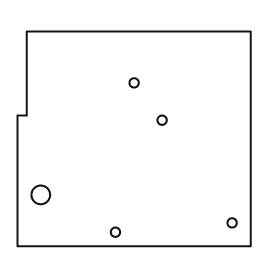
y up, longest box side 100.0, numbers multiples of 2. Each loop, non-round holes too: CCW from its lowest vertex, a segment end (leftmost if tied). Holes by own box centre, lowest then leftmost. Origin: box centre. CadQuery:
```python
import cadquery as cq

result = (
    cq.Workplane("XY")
    .moveTo(-50.0, -46.0)
    .lineTo(50.0, -46.0)
    .lineTo(50.0, 46.0)
    .lineTo(-46.0, 46.0)
    .lineTo(-46.0, 10.0)
    .lineTo(-50.0, 10.0)
    .close()
    .moveTo(-8.0, -40.0)
    .circle(2.0)
    .moveTo(42.0, -36.0)
    .circle(2.0)
    .moveTo(-40.0, -24.0)
    .circle(4.0)
    .moveTo(12.0, 8.0)
    .circle(2.0)
    .moveTo(0.0, 24.0)
    .circle(2.0)
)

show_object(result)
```